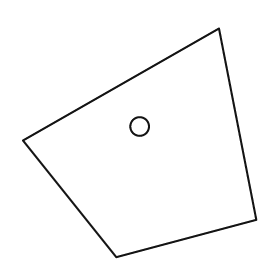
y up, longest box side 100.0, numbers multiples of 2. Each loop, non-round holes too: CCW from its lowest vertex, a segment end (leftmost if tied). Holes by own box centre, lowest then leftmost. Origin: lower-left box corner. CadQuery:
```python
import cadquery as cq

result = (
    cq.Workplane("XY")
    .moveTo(40.0, 0.0)
    .lineTo(100.0, 16.0)
    .lineTo(84.0, 98.0)
    .lineTo(0.0, 50.0)
    .close()
    .moveTo(50.0, 56.0)
    .circle(4.0)
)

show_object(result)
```